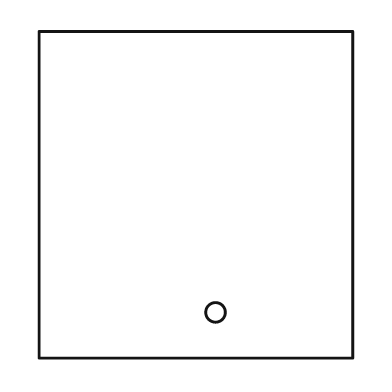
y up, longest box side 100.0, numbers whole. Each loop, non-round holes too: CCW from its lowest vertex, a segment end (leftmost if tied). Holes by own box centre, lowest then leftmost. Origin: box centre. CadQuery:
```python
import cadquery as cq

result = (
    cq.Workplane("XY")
    .moveTo(-48.0, -50.0)
    .lineTo(48.0, -50.0)
    .lineTo(48.0, 50.0)
    .lineTo(-48.0, 50.0)
    .close()
    .moveTo(6.0, -36.0)
    .circle(3.0)
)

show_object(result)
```